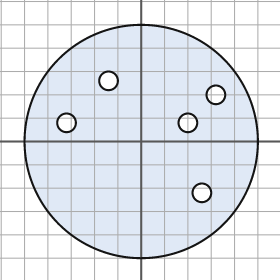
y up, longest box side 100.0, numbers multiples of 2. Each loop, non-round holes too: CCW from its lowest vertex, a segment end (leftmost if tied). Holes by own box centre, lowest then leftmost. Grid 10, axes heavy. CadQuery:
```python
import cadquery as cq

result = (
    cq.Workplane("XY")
    .moveTo(0.0, 0.0)
    .circle(50.0)
    .moveTo(26.0, -22.0)
    .circle(4.0)
    .moveTo(-32.0, 8.0)
    .circle(4.0)
    .moveTo(20.0, 8.0)
    .circle(4.0)
    .moveTo(32.0, 20.0)
    .circle(4.0)
    .moveTo(-14.0, 26.0)
    .circle(4.0)
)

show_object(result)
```